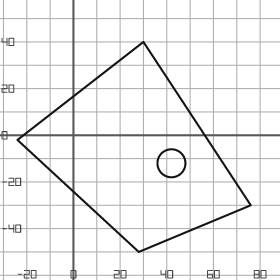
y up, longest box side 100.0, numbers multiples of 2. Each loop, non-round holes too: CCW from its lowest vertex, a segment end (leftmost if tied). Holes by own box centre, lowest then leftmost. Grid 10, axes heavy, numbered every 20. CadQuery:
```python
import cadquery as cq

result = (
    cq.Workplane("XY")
    .moveTo(28.0, -50.0)
    .lineTo(76.0, -30.0)
    .lineTo(30.0, 40.0)
    .lineTo(-24.0, -2.0)
    .close()
    .moveTo(42.0, -12.0)
    .circle(6.0)
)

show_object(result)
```